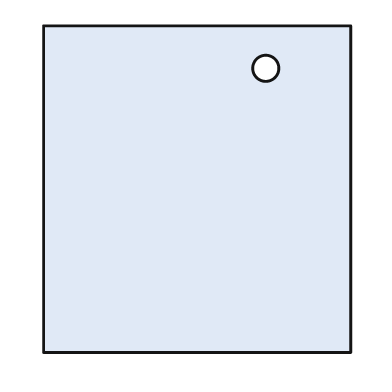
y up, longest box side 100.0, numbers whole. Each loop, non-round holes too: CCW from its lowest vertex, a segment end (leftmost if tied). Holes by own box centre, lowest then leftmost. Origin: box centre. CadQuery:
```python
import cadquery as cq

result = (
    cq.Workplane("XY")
    .moveTo(-47.0, -50.0)
    .lineTo(47.0, -50.0)
    .lineTo(47.0, 50.0)
    .lineTo(-47.0, 50.0)
    .close()
    .moveTo(21.0, 37.0)
    .circle(4.0)
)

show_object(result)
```